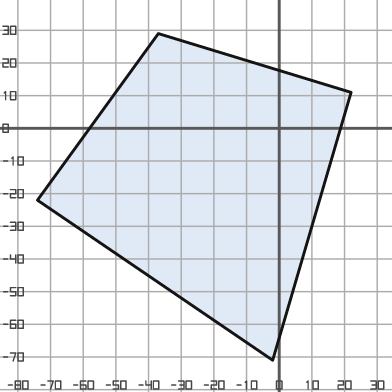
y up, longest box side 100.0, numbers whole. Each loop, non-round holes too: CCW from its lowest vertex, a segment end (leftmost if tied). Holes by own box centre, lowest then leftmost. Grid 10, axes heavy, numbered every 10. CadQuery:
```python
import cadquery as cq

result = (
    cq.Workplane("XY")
    .moveTo(-2.0, -71.0)
    .lineTo(22.0, 11.0)
    .lineTo(-37.0, 29.0)
    .lineTo(-74.0, -22.0)
    .close()
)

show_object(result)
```